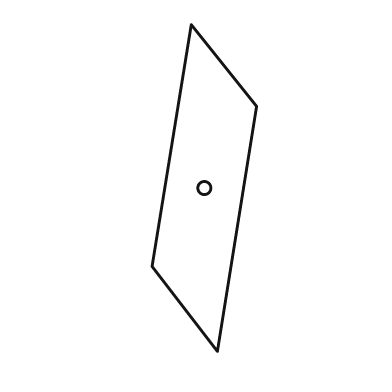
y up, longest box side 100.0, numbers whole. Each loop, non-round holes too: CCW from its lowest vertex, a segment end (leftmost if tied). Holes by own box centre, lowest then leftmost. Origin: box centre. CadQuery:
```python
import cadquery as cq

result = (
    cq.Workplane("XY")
    .moveTo(4.0, -50.0)
    .lineTo(16.0, 25.0)
    .lineTo(-4.0, 50.0)
    .lineTo(-16.0, -24.0)
    .close()
    .moveTo(0.0, 0.0)
    .circle(2.0)
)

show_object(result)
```